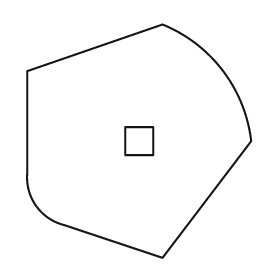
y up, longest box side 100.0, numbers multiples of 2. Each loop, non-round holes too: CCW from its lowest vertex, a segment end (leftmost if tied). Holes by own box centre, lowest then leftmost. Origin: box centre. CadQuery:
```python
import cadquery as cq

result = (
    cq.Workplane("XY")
    .moveTo(10.0, -50.0)
    .lineTo(48.0, 0.0)
    .threePointArc((36.0, 30.0), (10.0, 50.0))
    .lineTo(-48.0, 30.0)
    .lineTo(-48.0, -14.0)
    .threePointArc((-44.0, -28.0), (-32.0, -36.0))
    .close()
    .moveTo(-6.0, -6.0)
    .lineTo(6.0, -6.0)
    .lineTo(6.0, 6.0)
    .lineTo(-6.0, 6.0)
    .close()
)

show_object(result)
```